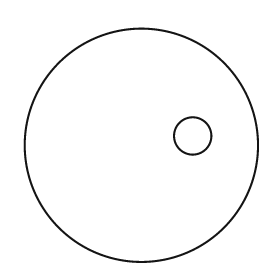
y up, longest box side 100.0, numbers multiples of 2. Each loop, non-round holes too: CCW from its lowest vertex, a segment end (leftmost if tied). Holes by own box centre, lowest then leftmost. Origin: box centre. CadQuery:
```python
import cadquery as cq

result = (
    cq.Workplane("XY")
    .moveTo(0.0, 0.0)
    .circle(50.0)
    .moveTo(22.0, 4.0)
    .circle(8.0)
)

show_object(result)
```